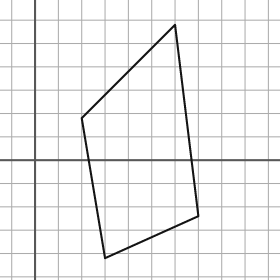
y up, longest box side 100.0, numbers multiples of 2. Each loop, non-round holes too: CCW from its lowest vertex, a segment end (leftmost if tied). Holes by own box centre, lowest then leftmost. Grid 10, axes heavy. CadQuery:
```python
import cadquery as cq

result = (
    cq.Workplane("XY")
    .moveTo(30.0, -42.0)
    .lineTo(70.0, -24.0)
    .lineTo(60.0, 58.0)
    .lineTo(20.0, 18.0)
    .close()
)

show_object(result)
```